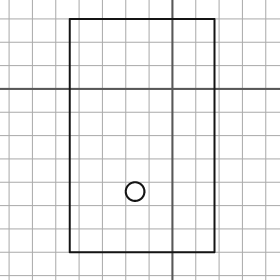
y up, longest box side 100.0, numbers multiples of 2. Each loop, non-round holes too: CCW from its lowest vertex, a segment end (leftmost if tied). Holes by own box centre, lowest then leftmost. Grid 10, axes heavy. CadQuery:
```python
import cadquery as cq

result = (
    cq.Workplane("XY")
    .moveTo(-44.0, -70.0)
    .lineTo(18.0, -70.0)
    .lineTo(18.0, 30.0)
    .lineTo(-44.0, 30.0)
    .close()
    .moveTo(-16.0, -44.0)
    .circle(4.0)
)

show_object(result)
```